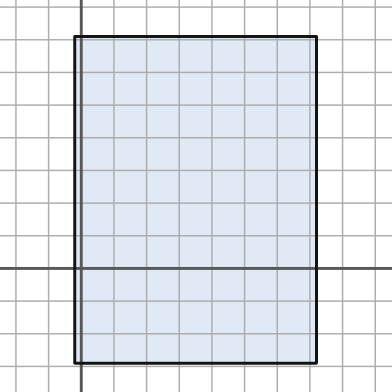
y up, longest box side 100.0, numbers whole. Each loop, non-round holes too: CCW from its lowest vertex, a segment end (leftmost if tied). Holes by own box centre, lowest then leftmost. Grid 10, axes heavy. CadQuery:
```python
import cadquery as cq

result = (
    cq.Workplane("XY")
    .moveTo(-2.0, -29.0)
    .lineTo(72.0, -29.0)
    .lineTo(72.0, 71.0)
    .lineTo(-2.0, 71.0)
    .close()
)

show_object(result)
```